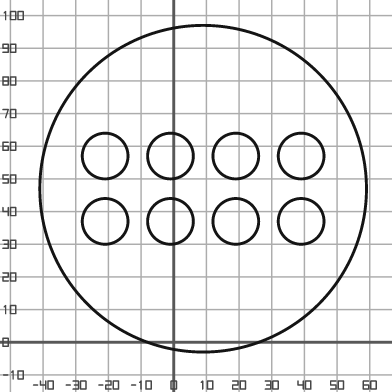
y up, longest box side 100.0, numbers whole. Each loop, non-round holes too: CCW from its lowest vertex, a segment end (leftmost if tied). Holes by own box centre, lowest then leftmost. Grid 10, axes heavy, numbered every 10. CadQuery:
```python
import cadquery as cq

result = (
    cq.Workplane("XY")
    .moveTo(9.0, 47.0)
    .circle(50.0)
    .moveTo(-21.0, 37.0)
    .circle(7.0)
    .moveTo(-1.0, 37.0)
    .circle(7.0)
    .moveTo(19.0, 37.0)
    .circle(7.0)
    .moveTo(39.0, 37.0)
    .circle(7.0)
    .moveTo(-21.0, 57.0)
    .circle(7.0)
    .moveTo(-1.0, 57.0)
    .circle(7.0)
    .moveTo(19.0, 57.0)
    .circle(7.0)
    .moveTo(39.0, 57.0)
    .circle(7.0)
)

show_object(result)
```